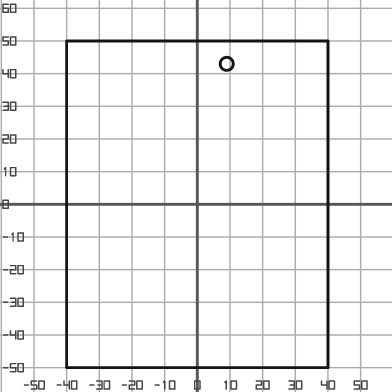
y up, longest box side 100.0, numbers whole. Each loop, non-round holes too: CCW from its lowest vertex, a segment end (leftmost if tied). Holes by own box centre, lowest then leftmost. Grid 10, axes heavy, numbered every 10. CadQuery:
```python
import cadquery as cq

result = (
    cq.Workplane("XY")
    .moveTo(-40.0, -50.0)
    .lineTo(40.0, -50.0)
    .lineTo(40.0, 50.0)
    .lineTo(-40.0, 50.0)
    .close()
    .moveTo(9.0, 43.0)
    .circle(2.0)
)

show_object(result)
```